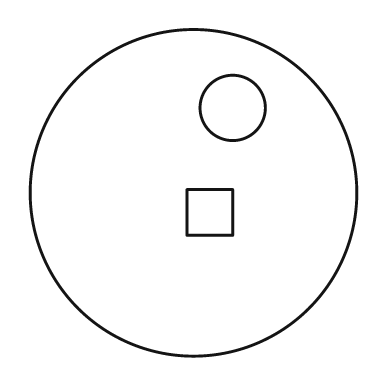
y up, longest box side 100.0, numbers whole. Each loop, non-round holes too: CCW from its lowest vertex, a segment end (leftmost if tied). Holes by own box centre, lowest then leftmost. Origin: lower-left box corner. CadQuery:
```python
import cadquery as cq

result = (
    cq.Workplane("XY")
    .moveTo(50.0, 50.0)
    .circle(50.0)
    .moveTo(48.0, 37.0)
    .lineTo(62.0, 37.0)
    .lineTo(62.0, 51.0)
    .lineTo(48.0, 51.0)
    .close()
    .moveTo(62.0, 76.0)
    .circle(10.0)
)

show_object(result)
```